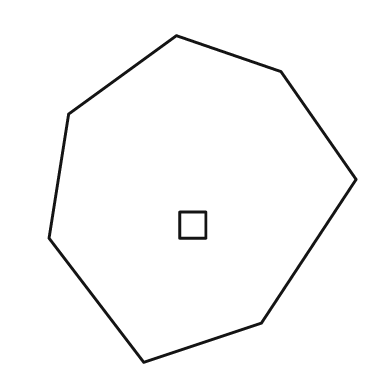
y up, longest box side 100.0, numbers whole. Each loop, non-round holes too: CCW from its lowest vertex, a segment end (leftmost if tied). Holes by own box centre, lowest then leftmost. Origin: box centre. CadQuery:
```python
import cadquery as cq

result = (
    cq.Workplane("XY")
    .moveTo(-18.0, -50.0)
    .lineTo(18.0, -38.0)
    .lineTo(47.0, 6.0)
    .lineTo(24.0, 39.0)
    .lineTo(-8.0, 50.0)
    .lineTo(-41.0, 26.0)
    .lineTo(-47.0, -12.0)
    .close()
    .moveTo(-7.0, -12.0)
    .lineTo(1.0, -12.0)
    .lineTo(1.0, -4.0)
    .lineTo(-7.0, -4.0)
    .close()
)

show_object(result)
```